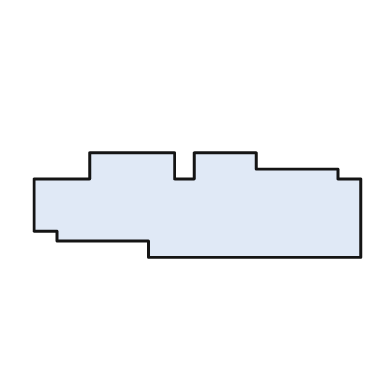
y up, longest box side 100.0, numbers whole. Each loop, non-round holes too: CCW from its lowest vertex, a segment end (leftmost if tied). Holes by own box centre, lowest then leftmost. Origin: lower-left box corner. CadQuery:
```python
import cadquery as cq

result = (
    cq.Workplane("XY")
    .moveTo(35.0, 0.0)
    .lineTo(100.0, 0.0)
    .lineTo(100.0, 24.0)
    .lineTo(93.0, 24.0)
    .lineTo(93.0, 27.0)
    .lineTo(68.0, 27.0)
    .lineTo(68.0, 32.0)
    .lineTo(49.0, 32.0)
    .lineTo(49.0, 24.0)
    .lineTo(43.0, 24.0)
    .lineTo(43.0, 32.0)
    .lineTo(17.0, 32.0)
    .lineTo(17.0, 24.0)
    .lineTo(0.0, 24.0)
    .lineTo(0.0, 8.0)
    .lineTo(7.0, 8.0)
    .lineTo(7.0, 5.0)
    .lineTo(35.0, 5.0)
    .close()
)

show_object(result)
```